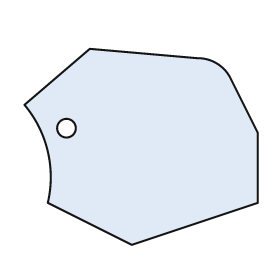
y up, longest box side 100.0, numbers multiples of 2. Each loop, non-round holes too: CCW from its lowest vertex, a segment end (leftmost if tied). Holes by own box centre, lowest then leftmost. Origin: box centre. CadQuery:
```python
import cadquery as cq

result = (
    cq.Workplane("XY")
    .moveTo(-4.0, -42.0)
    .lineTo(50.0, -24.0)
    .lineTo(50.0, 6.0)
    .lineTo(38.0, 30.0)
    .threePointArc((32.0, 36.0), (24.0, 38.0))
    .lineTo(-22.0, 42.0)
    .lineTo(-50.0, 18.0)
    .threePointArc((-40.0, -2.0), (-40.0, -24.0))
    .close()
    .moveTo(-32.0, 8.0)
    .circle(4.0)
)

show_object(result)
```